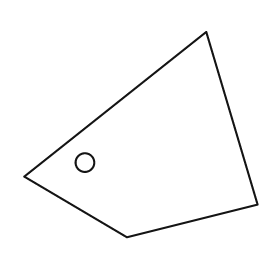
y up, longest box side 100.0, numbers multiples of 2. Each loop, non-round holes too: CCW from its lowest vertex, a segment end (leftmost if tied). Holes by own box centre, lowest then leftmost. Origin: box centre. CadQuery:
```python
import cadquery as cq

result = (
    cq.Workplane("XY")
    .moveTo(-6.0, -44.0)
    .lineTo(50.0, -30.0)
    .lineTo(28.0, 44.0)
    .lineTo(-50.0, -18.0)
    .close()
    .moveTo(-24.0, -12.0)
    .circle(4.0)
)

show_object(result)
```